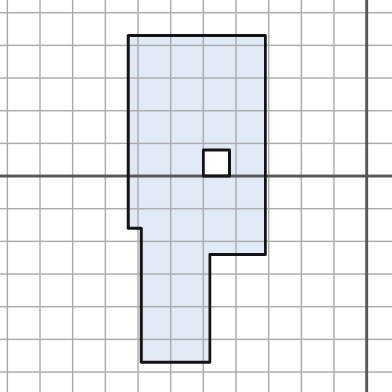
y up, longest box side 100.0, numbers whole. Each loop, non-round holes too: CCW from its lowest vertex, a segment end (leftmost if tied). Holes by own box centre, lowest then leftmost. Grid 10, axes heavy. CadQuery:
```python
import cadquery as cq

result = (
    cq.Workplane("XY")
    .moveTo(-69.0, -57.0)
    .lineTo(-48.0, -57.0)
    .lineTo(-48.0, -24.0)
    .lineTo(-31.0, -24.0)
    .lineTo(-31.0, 43.0)
    .lineTo(-73.0, 43.0)
    .lineTo(-73.0, -16.0)
    .lineTo(-69.0, -16.0)
    .close()
    .moveTo(-50.0, 0.0)
    .lineTo(-42.0, 0.0)
    .lineTo(-42.0, 8.0)
    .lineTo(-50.0, 8.0)
    .close()
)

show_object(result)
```